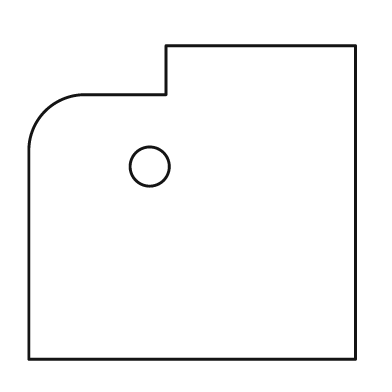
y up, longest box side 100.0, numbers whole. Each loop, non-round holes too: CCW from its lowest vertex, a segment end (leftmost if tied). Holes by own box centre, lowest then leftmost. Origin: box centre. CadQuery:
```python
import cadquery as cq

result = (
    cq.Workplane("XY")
    .moveTo(-50.0, -48.0)
    .lineTo(50.0, -48.0)
    .lineTo(50.0, 48.0)
    .lineTo(-8.0, 48.0)
    .lineTo(-8.0, 33.0)
    .lineTo(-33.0, 33.0)
    .threePointArc((-45.0, 28.0), (-50.0, 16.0))
    .close()
    .moveTo(-13.0, 11.0)
    .circle(6.0)
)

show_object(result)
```